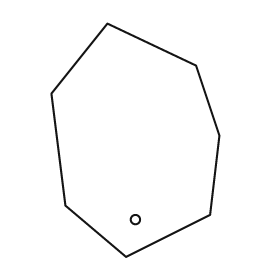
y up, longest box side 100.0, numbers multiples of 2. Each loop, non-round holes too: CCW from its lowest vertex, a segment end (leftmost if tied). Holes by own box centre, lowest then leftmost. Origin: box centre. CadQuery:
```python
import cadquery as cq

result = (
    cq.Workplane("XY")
    .moveTo(-4.0, -50.0)
    .lineTo(32.0, -32.0)
    .lineTo(36.0, 2.0)
    .lineTo(26.0, 32.0)
    .lineTo(-12.0, 50.0)
    .lineTo(-36.0, 20.0)
    .lineTo(-30.0, -28.0)
    .close()
    .moveTo(0.0, -34.0)
    .circle(2.0)
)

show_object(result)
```